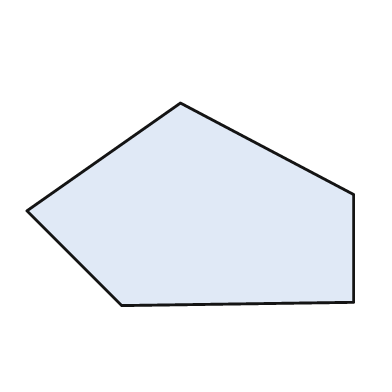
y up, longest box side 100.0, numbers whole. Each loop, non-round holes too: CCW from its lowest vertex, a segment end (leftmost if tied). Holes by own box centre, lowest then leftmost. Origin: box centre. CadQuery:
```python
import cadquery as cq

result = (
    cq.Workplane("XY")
    .moveTo(-21.0, -31.0)
    .lineTo(50.0, -30.0)
    .lineTo(50.0, 3.0)
    .lineTo(-3.0, 31.0)
    .lineTo(-50.0, -2.0)
    .close()
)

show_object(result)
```